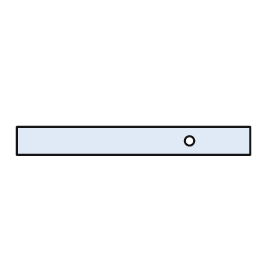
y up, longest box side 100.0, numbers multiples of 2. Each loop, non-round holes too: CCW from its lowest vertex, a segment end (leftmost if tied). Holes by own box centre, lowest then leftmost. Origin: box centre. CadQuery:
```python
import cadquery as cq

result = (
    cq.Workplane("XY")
    .moveTo(-50.0, -6.0)
    .lineTo(50.0, -6.0)
    .lineTo(50.0, 6.0)
    .lineTo(-50.0, 6.0)
    .close()
    .moveTo(24.0, 0.0)
    .circle(2.0)
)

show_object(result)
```